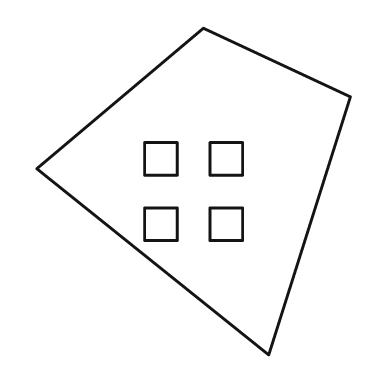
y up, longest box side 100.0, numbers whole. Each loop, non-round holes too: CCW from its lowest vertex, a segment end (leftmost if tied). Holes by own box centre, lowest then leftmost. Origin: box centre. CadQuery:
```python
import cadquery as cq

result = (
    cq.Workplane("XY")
    .moveTo(23.0, -50.0)
    .lineTo(48.0, 29.0)
    .lineTo(3.0, 50.0)
    .lineTo(-48.0, 7.0)
    .close()
    .moveTo(-15.0, -15.0)
    .lineTo(-5.0, -15.0)
    .lineTo(-5.0, -5.0)
    .lineTo(-15.0, -5.0)
    .close()
    .moveTo(5.0, -15.0)
    .lineTo(15.0, -15.0)
    .lineTo(15.0, -5.0)
    .lineTo(5.0, -5.0)
    .close()
    .moveTo(-15.0, 5.0)
    .lineTo(-5.0, 5.0)
    .lineTo(-5.0, 15.0)
    .lineTo(-15.0, 15.0)
    .close()
    .moveTo(5.0, 5.0)
    .lineTo(15.0, 5.0)
    .lineTo(15.0, 15.0)
    .lineTo(5.0, 15.0)
    .close()
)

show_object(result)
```